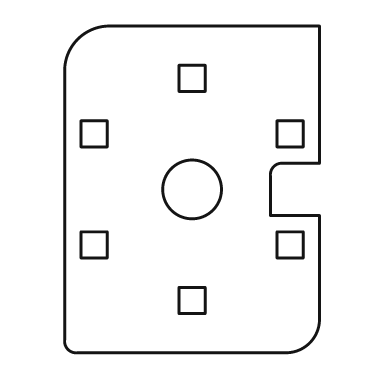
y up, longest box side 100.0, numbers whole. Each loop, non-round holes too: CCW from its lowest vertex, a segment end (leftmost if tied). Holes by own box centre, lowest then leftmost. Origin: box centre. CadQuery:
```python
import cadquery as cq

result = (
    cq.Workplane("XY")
    .moveTo(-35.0, -50.0)
    .lineTo(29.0, -50.0)
    .threePointArc((36.0, -47.0), (39.0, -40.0))
    .lineTo(39.0, -8.0)
    .lineTo(24.0, -8.0)
    .lineTo(24.0, 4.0)
    .threePointArc((25.0, 7.0), (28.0, 8.0))
    .lineTo(39.0, 8.0)
    .lineTo(39.0, 50.0)
    .lineTo(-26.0, 50.0)
    .threePointArc((-35.0, 46.0), (-39.0, 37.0))
    .lineTo(-39.0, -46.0)
    .threePointArc((-38.0, -49.0), (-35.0, -50.0))
    .close()
    .moveTo(-4.0, -38.0)
    .lineTo(4.0, -38.0)
    .lineTo(4.0, -30.0)
    .lineTo(-4.0, -30.0)
    .close()
    .moveTo(-34.0, -21.0)
    .lineTo(-26.0, -21.0)
    .lineTo(-26.0, -13.0)
    .lineTo(-34.0, -13.0)
    .close()
    .moveTo(26.0, -21.0)
    .lineTo(34.0, -21.0)
    .lineTo(34.0, -13.0)
    .lineTo(26.0, -13.0)
    .close()
    .moveTo(0.0, 0.0)
    .circle(9.0)
    .moveTo(-34.0, 13.0)
    .lineTo(-26.0, 13.0)
    .lineTo(-26.0, 21.0)
    .lineTo(-34.0, 21.0)
    .close()
    .moveTo(26.0, 13.0)
    .lineTo(34.0, 13.0)
    .lineTo(34.0, 21.0)
    .lineTo(26.0, 21.0)
    .close()
    .moveTo(-4.0, 30.0)
    .lineTo(4.0, 30.0)
    .lineTo(4.0, 38.0)
    .lineTo(-4.0, 38.0)
    .close()
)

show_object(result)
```